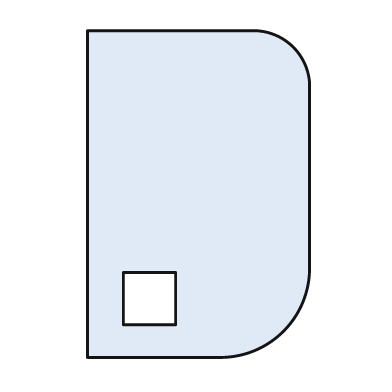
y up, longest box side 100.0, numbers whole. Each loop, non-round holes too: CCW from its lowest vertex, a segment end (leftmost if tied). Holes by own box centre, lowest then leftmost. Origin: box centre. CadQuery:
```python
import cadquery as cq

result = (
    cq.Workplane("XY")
    .moveTo(-34.0, -50.0)
    .lineTo(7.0, -50.0)
    .threePointArc((26.0, -42.0), (34.0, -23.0))
    .lineTo(34.0, 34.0)
    .threePointArc((29.0, 45.0), (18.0, 50.0))
    .lineTo(-34.0, 50.0)
    .close()
    .moveTo(-23.0, -40.0)
    .lineTo(-7.0, -40.0)
    .lineTo(-7.0, -24.0)
    .lineTo(-23.0, -24.0)
    .close()
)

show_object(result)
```